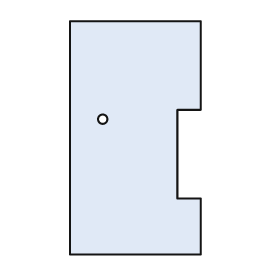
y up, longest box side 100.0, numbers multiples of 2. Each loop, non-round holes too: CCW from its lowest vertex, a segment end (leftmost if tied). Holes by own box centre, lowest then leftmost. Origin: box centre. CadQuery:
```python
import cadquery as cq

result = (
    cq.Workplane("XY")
    .moveTo(-28.0, -50.0)
    .lineTo(28.0, -50.0)
    .lineTo(28.0, -26.0)
    .lineTo(18.0, -26.0)
    .lineTo(18.0, 12.0)
    .lineTo(28.0, 12.0)
    .lineTo(28.0, 50.0)
    .lineTo(-28.0, 50.0)
    .close()
    .moveTo(-14.0, 8.0)
    .circle(2.0)
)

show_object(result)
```